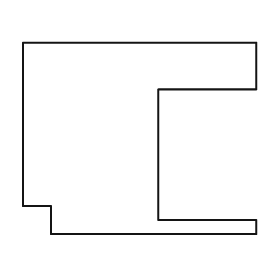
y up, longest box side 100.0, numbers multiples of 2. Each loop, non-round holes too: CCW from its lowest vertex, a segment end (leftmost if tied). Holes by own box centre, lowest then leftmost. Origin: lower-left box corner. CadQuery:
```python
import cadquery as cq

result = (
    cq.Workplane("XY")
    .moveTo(12.0, 0.0)
    .lineTo(100.0, 0.0)
    .lineTo(100.0, 6.0)
    .lineTo(58.0, 6.0)
    .lineTo(58.0, 62.0)
    .lineTo(100.0, 62.0)
    .lineTo(100.0, 82.0)
    .lineTo(0.0, 82.0)
    .lineTo(0.0, 12.0)
    .lineTo(12.0, 12.0)
    .close()
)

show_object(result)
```